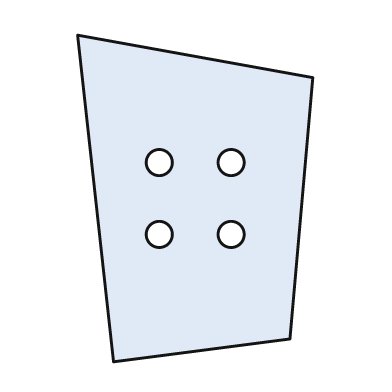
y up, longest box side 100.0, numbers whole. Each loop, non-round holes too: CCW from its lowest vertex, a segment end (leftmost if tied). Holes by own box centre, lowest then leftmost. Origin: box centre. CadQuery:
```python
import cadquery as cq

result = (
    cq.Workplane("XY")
    .moveTo(-25.0, -50.0)
    .lineTo(29.0, -43.0)
    .lineTo(36.0, 37.0)
    .lineTo(-36.0, 50.0)
    .close()
    .moveTo(-11.0, -11.0)
    .circle(4.0)
    .moveTo(11.0, -11.0)
    .circle(4.0)
    .moveTo(-11.0, 11.0)
    .circle(4.0)
    .moveTo(11.0, 11.0)
    .circle(4.0)
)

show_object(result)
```